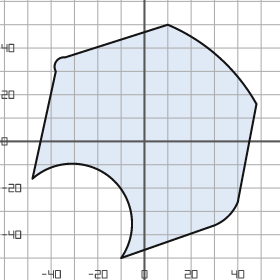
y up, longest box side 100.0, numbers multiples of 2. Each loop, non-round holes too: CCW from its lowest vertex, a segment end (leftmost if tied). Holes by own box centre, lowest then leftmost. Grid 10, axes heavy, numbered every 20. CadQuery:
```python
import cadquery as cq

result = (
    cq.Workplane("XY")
    .moveTo(-10.0, -50.0)
    .lineTo(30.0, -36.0)
    .threePointArc((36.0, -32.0), (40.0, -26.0))
    .lineTo(48.0, 16.0)
    .threePointArc((32.0, 36.0), (10.0, 50.0))
    .lineTo(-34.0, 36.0)
    .threePointArc((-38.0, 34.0), (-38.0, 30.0))
    .lineTo(-48.0, -16.0)
    .threePointArc((-14.0, -16.0), (-10.0, -50.0))
    .close()
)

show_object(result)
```